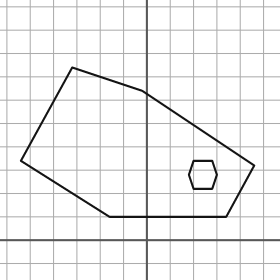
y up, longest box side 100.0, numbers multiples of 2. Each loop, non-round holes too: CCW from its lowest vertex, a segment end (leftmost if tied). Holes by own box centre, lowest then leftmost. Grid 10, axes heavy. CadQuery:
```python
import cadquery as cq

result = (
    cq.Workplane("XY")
    .moveTo(-16.0, 10.0)
    .lineTo(34.0, 10.0)
    .lineTo(46.0, 32.0)
    .lineTo(-2.0, 64.0)
    .lineTo(-32.0, 74.0)
    .lineTo(-54.0, 34.0)
    .close()
    .moveTo(20.0, 22.0)
    .lineTo(28.0, 22.0)
    .lineTo(30.0, 28.0)
    .lineTo(28.0, 34.0)
    .lineTo(20.0, 34.0)
    .lineTo(18.0, 28.0)
    .close()
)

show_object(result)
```